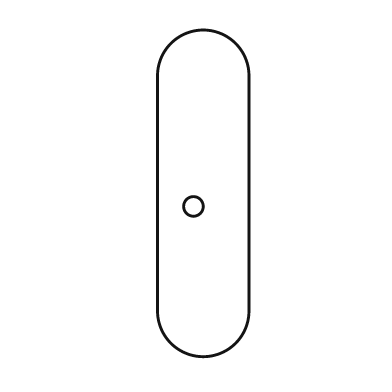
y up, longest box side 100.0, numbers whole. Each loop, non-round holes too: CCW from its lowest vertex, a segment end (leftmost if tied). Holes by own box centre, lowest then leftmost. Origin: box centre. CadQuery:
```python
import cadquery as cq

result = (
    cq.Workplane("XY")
    .moveTo(-14.0, -36.0)
    .threePointArc((0.0, -50.0), (14.0, -36.0))
    .lineTo(14.0, 36.0)
    .threePointArc((0.0, 50.0), (-14.0, 36.0))
    .close()
    .moveTo(-3.0, -4.0)
    .circle(3.0)
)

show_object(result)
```